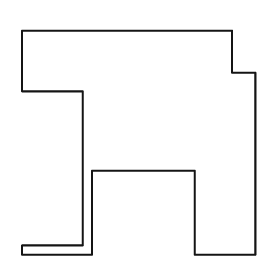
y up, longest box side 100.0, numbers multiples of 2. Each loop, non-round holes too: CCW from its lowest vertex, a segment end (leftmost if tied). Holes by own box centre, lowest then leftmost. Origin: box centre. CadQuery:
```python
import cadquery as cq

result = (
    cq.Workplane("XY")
    .moveTo(-50.0, -48.0)
    .lineTo(-20.0, -48.0)
    .lineTo(-20.0, -12.0)
    .lineTo(24.0, -12.0)
    .lineTo(24.0, -48.0)
    .lineTo(50.0, -48.0)
    .lineTo(50.0, 30.0)
    .lineTo(40.0, 30.0)
    .lineTo(40.0, 48.0)
    .lineTo(-50.0, 48.0)
    .lineTo(-50.0, 22.0)
    .lineTo(-24.0, 22.0)
    .lineTo(-24.0, -44.0)
    .lineTo(-50.0, -44.0)
    .close()
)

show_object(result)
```